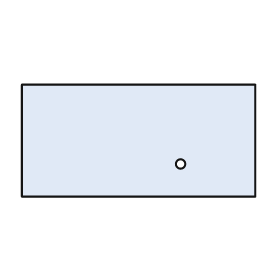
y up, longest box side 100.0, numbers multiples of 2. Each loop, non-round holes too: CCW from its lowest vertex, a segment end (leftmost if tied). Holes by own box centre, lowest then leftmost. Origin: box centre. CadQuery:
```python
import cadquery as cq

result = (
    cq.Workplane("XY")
    .moveTo(-50.0, -24.0)
    .lineTo(50.0, -24.0)
    .lineTo(50.0, 24.0)
    .lineTo(-50.0, 24.0)
    .close()
    .moveTo(18.0, -10.0)
    .circle(2.0)
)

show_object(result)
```